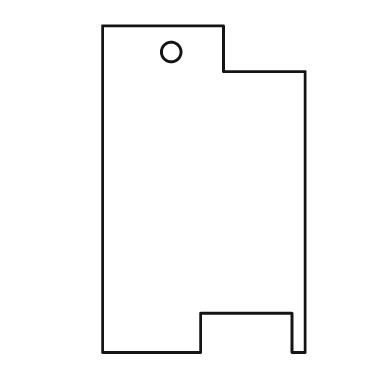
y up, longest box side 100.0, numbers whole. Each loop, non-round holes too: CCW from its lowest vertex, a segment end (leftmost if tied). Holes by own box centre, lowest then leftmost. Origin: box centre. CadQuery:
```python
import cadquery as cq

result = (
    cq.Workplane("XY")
    .moveTo(-31.0, -50.0)
    .lineTo(-1.0, -50.0)
    .lineTo(-1.0, -38.0)
    .lineTo(27.0, -38.0)
    .lineTo(27.0, -50.0)
    .lineTo(31.0, -50.0)
    .lineTo(31.0, 36.0)
    .lineTo(6.0, 36.0)
    .lineTo(6.0, 50.0)
    .lineTo(-31.0, 50.0)
    .close()
    .moveTo(-10.0, 42.0)
    .circle(3.0)
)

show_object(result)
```